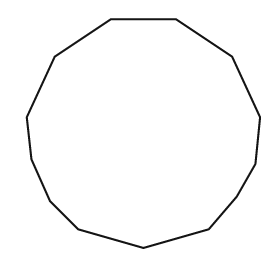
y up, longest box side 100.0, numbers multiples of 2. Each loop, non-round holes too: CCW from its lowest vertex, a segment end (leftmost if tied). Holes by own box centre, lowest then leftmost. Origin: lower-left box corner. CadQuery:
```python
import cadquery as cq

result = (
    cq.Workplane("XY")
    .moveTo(50.0, 0.0)
    .lineTo(78.0, 8.0)
    .lineTo(90.0, 22.0)
    .lineTo(98.0, 36.0)
    .lineTo(100.0, 56.0)
    .lineTo(88.0, 82.0)
    .lineTo(64.0, 98.0)
    .lineTo(36.0, 98.0)
    .lineTo(12.0, 82.0)
    .lineTo(0.0, 56.0)
    .lineTo(2.0, 38.0)
    .lineTo(10.0, 20.0)
    .lineTo(22.0, 8.0)
    .close()
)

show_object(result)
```